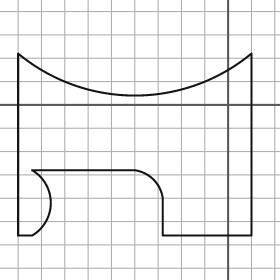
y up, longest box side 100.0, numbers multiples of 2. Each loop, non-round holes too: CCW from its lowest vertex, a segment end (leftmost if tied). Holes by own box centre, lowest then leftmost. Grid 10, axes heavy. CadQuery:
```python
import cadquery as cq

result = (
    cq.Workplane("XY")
    .moveTo(-90.0, -56.0)
    .lineTo(-84.0, -56.0)
    .threePointArc((-76.0, -42.0), (-84.0, -28.0))
    .lineTo(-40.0, -28.0)
    .threePointArc((-32.0, -32.0), (-28.0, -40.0))
    .lineTo(-28.0, -56.0)
    .lineTo(10.0, -56.0)
    .lineTo(10.0, 22.0)
    .threePointArc((-40.0, 4.0), (-90.0, 22.0))
    .close()
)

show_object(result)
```